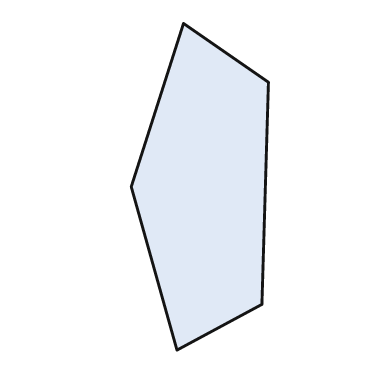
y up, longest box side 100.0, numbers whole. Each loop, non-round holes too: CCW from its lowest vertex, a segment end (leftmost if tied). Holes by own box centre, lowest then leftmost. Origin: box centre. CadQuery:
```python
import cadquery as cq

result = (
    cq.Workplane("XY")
    .moveTo(-7.0, -50.0)
    .lineTo(19.0, -36.0)
    .lineTo(21.0, 32.0)
    .lineTo(-5.0, 50.0)
    .lineTo(-21.0, 0.0)
    .close()
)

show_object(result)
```